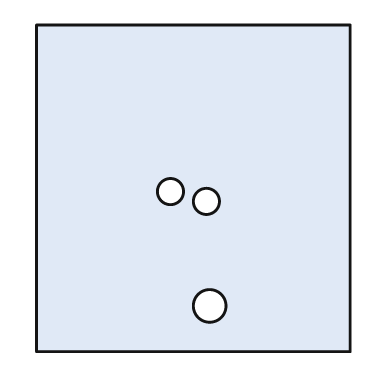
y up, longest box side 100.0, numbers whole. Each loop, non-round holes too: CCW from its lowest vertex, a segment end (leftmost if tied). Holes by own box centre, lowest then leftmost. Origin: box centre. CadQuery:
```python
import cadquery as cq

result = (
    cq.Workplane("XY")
    .moveTo(-48.0, -50.0)
    .lineTo(48.0, -50.0)
    .lineTo(48.0, 50.0)
    .lineTo(-48.0, 50.0)
    .close()
    .moveTo(5.0, -36.0)
    .circle(5.0)
    .moveTo(4.0, -4.0)
    .circle(4.0)
    .moveTo(-7.0, -1.0)
    .circle(4.0)
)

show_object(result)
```